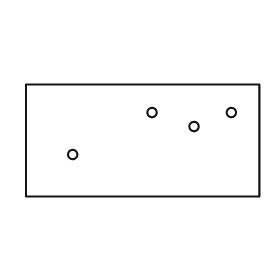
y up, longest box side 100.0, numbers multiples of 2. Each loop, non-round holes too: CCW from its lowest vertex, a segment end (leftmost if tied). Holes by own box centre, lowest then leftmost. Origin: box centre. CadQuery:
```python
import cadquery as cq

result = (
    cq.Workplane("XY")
    .moveTo(-50.0, -24.0)
    .lineTo(50.0, -24.0)
    .lineTo(50.0, 24.0)
    .lineTo(-50.0, 24.0)
    .close()
    .moveTo(-30.0, -6.0)
    .circle(2.0)
    .moveTo(22.0, 6.0)
    .circle(2.0)
    .moveTo(4.0, 12.0)
    .circle(2.0)
    .moveTo(38.0, 12.0)
    .circle(2.0)
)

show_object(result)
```